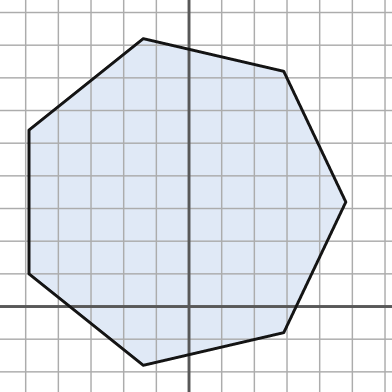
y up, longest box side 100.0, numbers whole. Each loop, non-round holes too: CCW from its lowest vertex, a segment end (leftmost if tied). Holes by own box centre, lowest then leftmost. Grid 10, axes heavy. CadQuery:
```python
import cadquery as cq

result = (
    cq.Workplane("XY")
    .moveTo(-14.0, -18.0)
    .lineTo(29.0, -8.0)
    .lineTo(48.0, 32.0)
    .lineTo(29.0, 72.0)
    .lineTo(-14.0, 82.0)
    .lineTo(-49.0, 54.0)
    .lineTo(-49.0, 10.0)
    .close()
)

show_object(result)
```